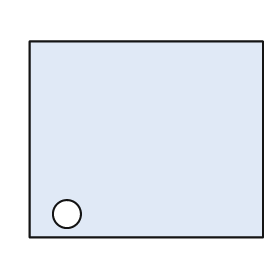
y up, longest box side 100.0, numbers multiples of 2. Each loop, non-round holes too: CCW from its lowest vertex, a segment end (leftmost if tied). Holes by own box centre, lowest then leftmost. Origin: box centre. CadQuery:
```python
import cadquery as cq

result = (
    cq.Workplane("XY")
    .moveTo(-50.0, -42.0)
    .lineTo(50.0, -42.0)
    .lineTo(50.0, 42.0)
    .lineTo(-50.0, 42.0)
    .close()
    .moveTo(-34.0, -32.0)
    .circle(6.0)
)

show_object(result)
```